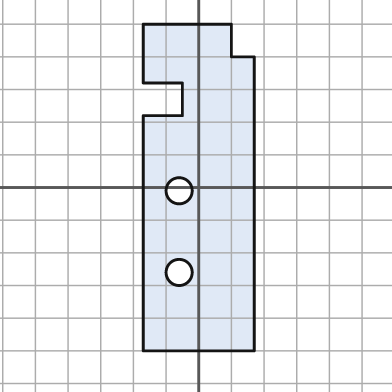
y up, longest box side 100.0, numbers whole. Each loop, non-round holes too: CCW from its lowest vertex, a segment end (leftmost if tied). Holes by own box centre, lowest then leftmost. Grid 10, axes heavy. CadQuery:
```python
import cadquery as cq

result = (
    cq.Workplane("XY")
    .moveTo(-17.0, -50.0)
    .lineTo(17.0, -50.0)
    .lineTo(17.0, 40.0)
    .lineTo(10.0, 40.0)
    .lineTo(10.0, 50.0)
    .lineTo(-17.0, 50.0)
    .lineTo(-17.0, 32.0)
    .lineTo(-5.0, 32.0)
    .lineTo(-5.0, 22.0)
    .lineTo(-17.0, 22.0)
    .close()
    .moveTo(-6.0, -26.0)
    .circle(4.0)
    .moveTo(-6.0, -1.0)
    .circle(4.0)
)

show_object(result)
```